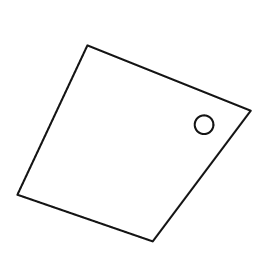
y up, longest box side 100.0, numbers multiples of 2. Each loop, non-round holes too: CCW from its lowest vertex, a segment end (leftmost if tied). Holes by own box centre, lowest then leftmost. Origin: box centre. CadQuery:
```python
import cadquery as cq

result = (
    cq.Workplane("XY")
    .moveTo(8.0, -42.0)
    .lineTo(50.0, 14.0)
    .lineTo(-20.0, 42.0)
    .lineTo(-50.0, -22.0)
    .close()
    .moveTo(30.0, 8.0)
    .circle(4.0)
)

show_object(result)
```